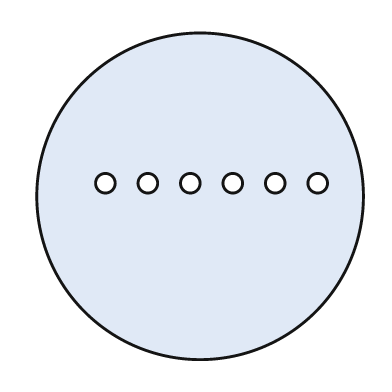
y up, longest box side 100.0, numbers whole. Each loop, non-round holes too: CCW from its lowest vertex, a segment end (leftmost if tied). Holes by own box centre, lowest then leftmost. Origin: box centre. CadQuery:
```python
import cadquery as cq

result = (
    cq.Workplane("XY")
    .moveTo(0.0, 0.0)
    .circle(50.0)
    .moveTo(-29.0, 4.0)
    .circle(3.0)
    .moveTo(-16.0, 4.0)
    .circle(3.0)
    .moveTo(-3.0, 4.0)
    .circle(3.0)
    .moveTo(10.0, 4.0)
    .circle(3.0)
    .moveTo(23.0, 4.0)
    .circle(3.0)
    .moveTo(36.0, 4.0)
    .circle(3.0)
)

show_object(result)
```